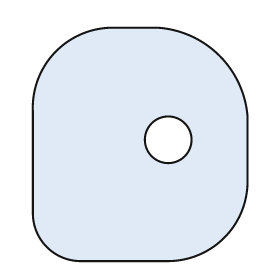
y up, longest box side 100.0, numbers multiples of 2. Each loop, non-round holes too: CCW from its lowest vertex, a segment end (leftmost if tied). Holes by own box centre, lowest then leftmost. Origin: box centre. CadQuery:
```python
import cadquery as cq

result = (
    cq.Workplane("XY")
    .moveTo(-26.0, -50.0)
    .lineTo(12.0, -50.0)
    .threePointArc((36.0, -40.0), (46.0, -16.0))
    .lineTo(46.0, 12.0)
    .threePointArc((34.0, 38.0), (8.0, 50.0))
    .lineTo(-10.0, 50.0)
    .threePointArc((-36.0, 40.0), (-46.0, 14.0))
    .lineTo(-46.0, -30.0)
    .threePointArc((-40.0, -44.0), (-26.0, -50.0))
    .close()
    .moveTo(12.0, 2.0)
    .circle(10.0)
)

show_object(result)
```